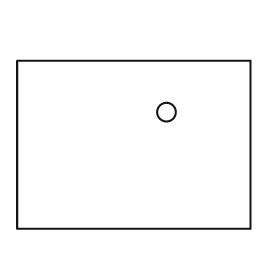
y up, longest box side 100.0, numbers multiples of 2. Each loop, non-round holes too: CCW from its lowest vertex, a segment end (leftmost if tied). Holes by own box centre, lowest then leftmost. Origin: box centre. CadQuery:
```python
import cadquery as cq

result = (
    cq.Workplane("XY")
    .moveTo(-50.0, -36.0)
    .lineTo(50.0, -36.0)
    .lineTo(50.0, 36.0)
    .lineTo(-50.0, 36.0)
    .close()
    .moveTo(14.0, 14.0)
    .circle(4.0)
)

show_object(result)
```